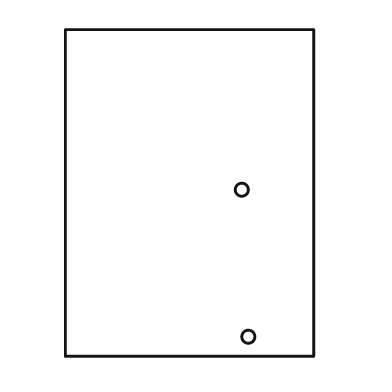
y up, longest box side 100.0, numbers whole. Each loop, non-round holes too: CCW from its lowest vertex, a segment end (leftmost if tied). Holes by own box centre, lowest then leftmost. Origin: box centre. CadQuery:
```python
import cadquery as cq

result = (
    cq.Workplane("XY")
    .moveTo(-38.0, -50.0)
    .lineTo(38.0, -50.0)
    .lineTo(38.0, 50.0)
    .lineTo(-38.0, 50.0)
    .close()
    .moveTo(18.0, -44.0)
    .circle(2.0)
    .moveTo(16.0, 1.0)
    .circle(2.0)
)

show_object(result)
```